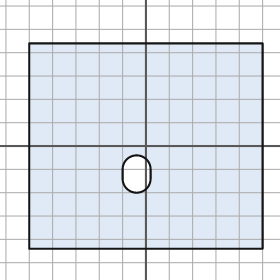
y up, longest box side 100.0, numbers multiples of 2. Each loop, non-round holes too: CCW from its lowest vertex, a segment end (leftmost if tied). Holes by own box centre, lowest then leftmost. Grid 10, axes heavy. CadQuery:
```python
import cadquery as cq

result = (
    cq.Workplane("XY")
    .moveTo(-50.0, -44.0)
    .lineTo(50.0, -44.0)
    .lineTo(50.0, 44.0)
    .lineTo(-50.0, 44.0)
    .close()
    .moveTo(-10.0, -14.0)
    .threePointArc((-4.0, -20.0), (2.0, -14.0))
    .lineTo(2.0, -10.0)
    .threePointArc((-4.0, -4.0), (-10.0, -10.0))
    .close()
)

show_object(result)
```